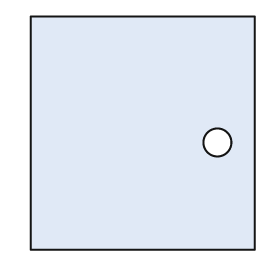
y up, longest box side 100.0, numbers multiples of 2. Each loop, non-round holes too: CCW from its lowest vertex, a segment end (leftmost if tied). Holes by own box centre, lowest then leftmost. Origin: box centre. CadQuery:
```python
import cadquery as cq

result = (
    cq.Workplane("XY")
    .moveTo(-48.0, -50.0)
    .lineTo(48.0, -50.0)
    .lineTo(48.0, 50.0)
    .lineTo(-48.0, 50.0)
    .close()
    .moveTo(32.0, -4.0)
    .circle(6.0)
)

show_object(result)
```